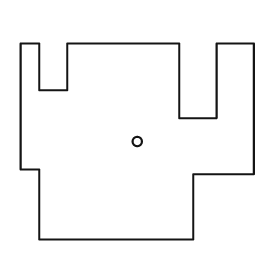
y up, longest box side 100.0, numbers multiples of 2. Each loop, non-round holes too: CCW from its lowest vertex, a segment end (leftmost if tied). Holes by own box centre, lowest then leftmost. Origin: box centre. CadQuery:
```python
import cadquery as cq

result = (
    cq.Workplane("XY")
    .moveTo(-42.0, -42.0)
    .lineTo(24.0, -42.0)
    .lineTo(24.0, -14.0)
    .lineTo(50.0, -14.0)
    .lineTo(50.0, 42.0)
    .lineTo(34.0, 42.0)
    .lineTo(34.0, 10.0)
    .lineTo(18.0, 10.0)
    .lineTo(18.0, 42.0)
    .lineTo(-30.0, 42.0)
    .lineTo(-30.0, 22.0)
    .lineTo(-42.0, 22.0)
    .lineTo(-42.0, 42.0)
    .lineTo(-50.0, 42.0)
    .lineTo(-50.0, -12.0)
    .lineTo(-42.0, -12.0)
    .close()
    .moveTo(0.0, 0.0)
    .circle(2.0)
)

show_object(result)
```